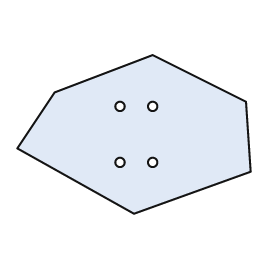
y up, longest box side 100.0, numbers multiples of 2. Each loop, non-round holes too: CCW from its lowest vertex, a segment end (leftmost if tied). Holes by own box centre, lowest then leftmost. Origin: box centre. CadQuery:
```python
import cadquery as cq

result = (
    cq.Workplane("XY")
    .moveTo(0.0, -34.0)
    .lineTo(50.0, -16.0)
    .lineTo(48.0, 14.0)
    .lineTo(8.0, 34.0)
    .lineTo(-34.0, 18.0)
    .lineTo(-50.0, -6.0)
    .close()
    .moveTo(-6.0, -12.0)
    .circle(2.0)
    .moveTo(8.0, -12.0)
    .circle(2.0)
    .moveTo(-6.0, 12.0)
    .circle(2.0)
    .moveTo(8.0, 12.0)
    .circle(2.0)
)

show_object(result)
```